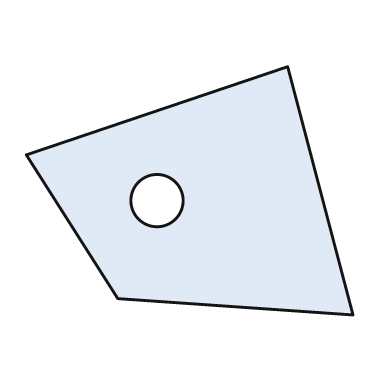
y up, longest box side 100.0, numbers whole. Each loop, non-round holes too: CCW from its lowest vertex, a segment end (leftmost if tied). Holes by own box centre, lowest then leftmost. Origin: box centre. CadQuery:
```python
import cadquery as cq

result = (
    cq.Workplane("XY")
    .moveTo(50.0, -38.0)
    .lineTo(30.0, 38.0)
    .lineTo(-50.0, 11.0)
    .lineTo(-22.0, -33.0)
    .close()
    .moveTo(-10.0, -3.0)
    .circle(8.0)
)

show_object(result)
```